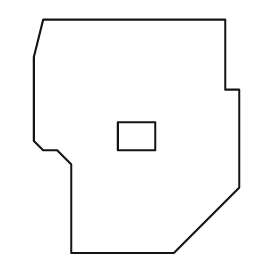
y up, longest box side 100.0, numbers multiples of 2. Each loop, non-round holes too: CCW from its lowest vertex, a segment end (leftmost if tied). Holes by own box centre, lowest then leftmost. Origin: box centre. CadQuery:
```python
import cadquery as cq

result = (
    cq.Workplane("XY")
    .moveTo(-28.0, -50.0)
    .lineTo(16.0, -50.0)
    .lineTo(44.0, -22.0)
    .lineTo(44.0, 20.0)
    .lineTo(38.0, 20.0)
    .lineTo(38.0, 50.0)
    .lineTo(-40.0, 50.0)
    .lineTo(-44.0, 34.0)
    .lineTo(-44.0, -2.0)
    .lineTo(-40.0, -6.0)
    .lineTo(-34.0, -6.0)
    .lineTo(-28.0, -12.0)
    .close()
    .moveTo(-8.0, -6.0)
    .lineTo(8.0, -6.0)
    .lineTo(8.0, 6.0)
    .lineTo(-8.0, 6.0)
    .close()
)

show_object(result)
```